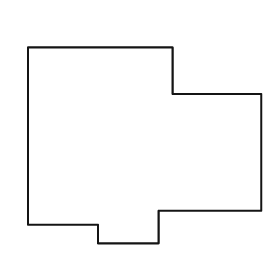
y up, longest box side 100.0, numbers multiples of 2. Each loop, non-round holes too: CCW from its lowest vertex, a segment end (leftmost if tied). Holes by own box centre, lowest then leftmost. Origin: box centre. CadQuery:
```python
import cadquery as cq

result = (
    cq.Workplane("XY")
    .moveTo(-20.0, -42.0)
    .lineTo(6.0, -42.0)
    .lineTo(6.0, -28.0)
    .lineTo(50.0, -28.0)
    .lineTo(50.0, 22.0)
    .lineTo(12.0, 22.0)
    .lineTo(12.0, 42.0)
    .lineTo(-50.0, 42.0)
    .lineTo(-50.0, -34.0)
    .lineTo(-20.0, -34.0)
    .close()
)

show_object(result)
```